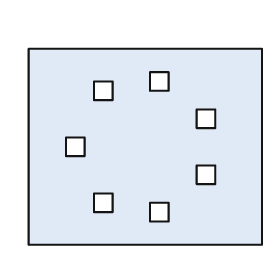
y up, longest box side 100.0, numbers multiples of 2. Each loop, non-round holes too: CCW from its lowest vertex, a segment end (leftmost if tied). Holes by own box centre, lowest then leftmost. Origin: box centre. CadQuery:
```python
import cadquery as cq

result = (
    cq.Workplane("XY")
    .moveTo(-50.0, -42.0)
    .lineTo(50.0, -42.0)
    .lineTo(50.0, 42.0)
    .lineTo(-50.0, 42.0)
    .close()
    .moveTo(2.0, -32.0)
    .lineTo(10.0, -32.0)
    .lineTo(10.0, -24.0)
    .lineTo(2.0, -24.0)
    .close()
    .moveTo(-22.0, -28.0)
    .lineTo(-14.0, -28.0)
    .lineTo(-14.0, -20.0)
    .lineTo(-22.0, -20.0)
    .close()
    .moveTo(22.0, -16.0)
    .lineTo(30.0, -16.0)
    .lineTo(30.0, -8.0)
    .lineTo(22.0, -8.0)
    .close()
    .moveTo(-34.0, -4.0)
    .lineTo(-26.0, -4.0)
    .lineTo(-26.0, 4.0)
    .lineTo(-34.0, 4.0)
    .close()
    .moveTo(22.0, 8.0)
    .lineTo(30.0, 8.0)
    .lineTo(30.0, 16.0)
    .lineTo(22.0, 16.0)
    .close()
    .moveTo(-22.0, 20.0)
    .lineTo(-14.0, 20.0)
    .lineTo(-14.0, 28.0)
    .lineTo(-22.0, 28.0)
    .close()
    .moveTo(2.0, 24.0)
    .lineTo(10.0, 24.0)
    .lineTo(10.0, 32.0)
    .lineTo(2.0, 32.0)
    .close()
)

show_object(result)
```